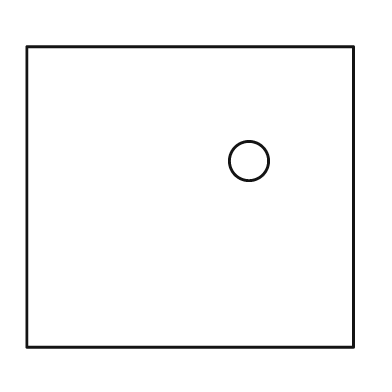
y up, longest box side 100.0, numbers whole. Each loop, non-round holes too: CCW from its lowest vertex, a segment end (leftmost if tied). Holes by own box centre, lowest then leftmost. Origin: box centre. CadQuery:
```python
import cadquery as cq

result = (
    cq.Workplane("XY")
    .moveTo(-50.0, -46.0)
    .lineTo(50.0, -46.0)
    .lineTo(50.0, 46.0)
    .lineTo(-50.0, 46.0)
    .close()
    .moveTo(18.0, 11.0)
    .circle(6.0)
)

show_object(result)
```